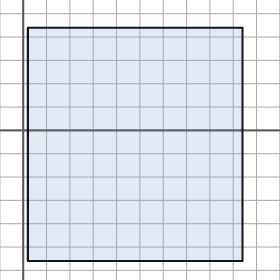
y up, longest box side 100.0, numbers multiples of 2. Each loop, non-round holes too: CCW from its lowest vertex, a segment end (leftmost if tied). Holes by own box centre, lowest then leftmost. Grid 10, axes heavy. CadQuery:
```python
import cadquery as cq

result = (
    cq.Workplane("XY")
    .moveTo(2.0, -56.0)
    .lineTo(94.0, -56.0)
    .lineTo(94.0, 44.0)
    .lineTo(2.0, 44.0)
    .close()
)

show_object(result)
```